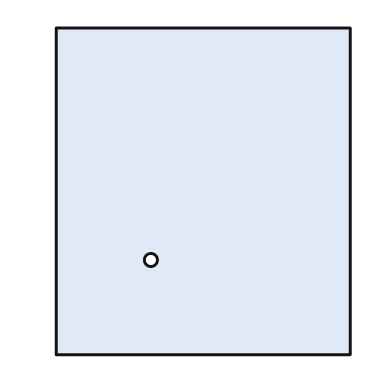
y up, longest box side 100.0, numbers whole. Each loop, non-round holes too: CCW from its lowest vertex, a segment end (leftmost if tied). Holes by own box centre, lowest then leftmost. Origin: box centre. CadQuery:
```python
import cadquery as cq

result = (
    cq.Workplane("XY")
    .moveTo(-45.0, -50.0)
    .lineTo(45.0, -50.0)
    .lineTo(45.0, 50.0)
    .lineTo(-45.0, 50.0)
    .close()
    .moveTo(-16.0, -21.0)
    .circle(2.0)
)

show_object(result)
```